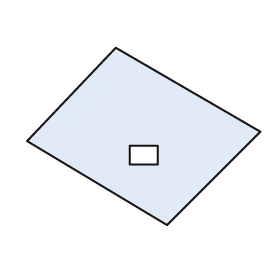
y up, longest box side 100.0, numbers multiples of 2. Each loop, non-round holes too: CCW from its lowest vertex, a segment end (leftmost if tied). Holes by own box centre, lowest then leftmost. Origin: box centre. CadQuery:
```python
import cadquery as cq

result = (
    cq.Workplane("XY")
    .moveTo(10.0, -38.0)
    .lineTo(50.0, 2.0)
    .lineTo(-12.0, 38.0)
    .lineTo(-50.0, -2.0)
    .close()
    .moveTo(-6.0, -12.0)
    .lineTo(6.0, -12.0)
    .lineTo(6.0, -4.0)
    .lineTo(-6.0, -4.0)
    .close()
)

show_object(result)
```